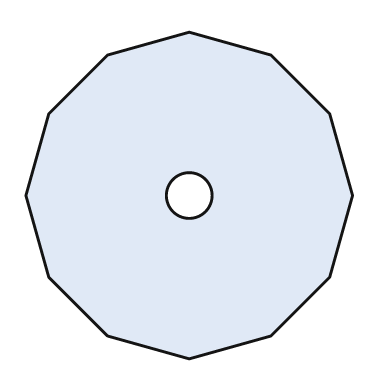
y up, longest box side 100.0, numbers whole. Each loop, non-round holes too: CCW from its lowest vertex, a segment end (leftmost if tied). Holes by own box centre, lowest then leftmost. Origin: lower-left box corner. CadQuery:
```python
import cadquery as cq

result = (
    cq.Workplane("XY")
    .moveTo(50.0, 0.0)
    .lineTo(75.0, 7.0)
    .lineTo(93.0, 25.0)
    .lineTo(100.0, 50.0)
    .lineTo(93.0, 75.0)
    .lineTo(75.0, 93.0)
    .lineTo(50.0, 100.0)
    .lineTo(25.0, 93.0)
    .lineTo(7.0, 75.0)
    .lineTo(0.0, 50.0)
    .lineTo(7.0, 25.0)
    .lineTo(25.0, 7.0)
    .close()
    .moveTo(50.0, 50.0)
    .circle(7.0)
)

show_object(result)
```